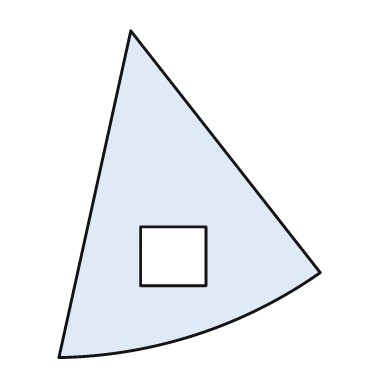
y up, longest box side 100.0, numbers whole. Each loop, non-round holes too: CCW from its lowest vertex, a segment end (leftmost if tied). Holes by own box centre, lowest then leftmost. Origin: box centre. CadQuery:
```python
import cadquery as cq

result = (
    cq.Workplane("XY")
    .moveTo(-40.0, -50.0)
    .threePointArc((2.0, -43.0), (40.0, -24.0))
    .lineTo(-18.0, 50.0)
    .close()
    .moveTo(-15.0, -28.0)
    .lineTo(5.0, -28.0)
    .lineTo(5.0, -10.0)
    .lineTo(-15.0, -10.0)
    .close()
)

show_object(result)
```